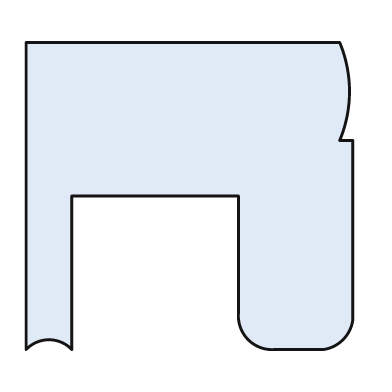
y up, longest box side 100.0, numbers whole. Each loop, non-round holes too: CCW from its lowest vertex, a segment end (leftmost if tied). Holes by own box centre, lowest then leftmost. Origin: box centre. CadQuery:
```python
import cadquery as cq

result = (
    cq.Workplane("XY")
    .moveTo(-50.0, -47.0)
    .threePointArc((-43.0, -44.0), (-36.0, -47.0))
    .lineTo(-36.0, 0.0)
    .lineTo(15.0, 0.0)
    .lineTo(15.0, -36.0)
    .threePointArc((18.0, -44.0), (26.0, -47.0))
    .lineTo(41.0, -47.0)
    .threePointArc((47.0, -44.0), (50.0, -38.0))
    .lineTo(50.0, 17.0)
    .lineTo(46.0, 17.0)
    .threePointArc((49.0, 32.0), (46.0, 47.0))
    .lineTo(-50.0, 47.0)
    .close()
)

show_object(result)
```